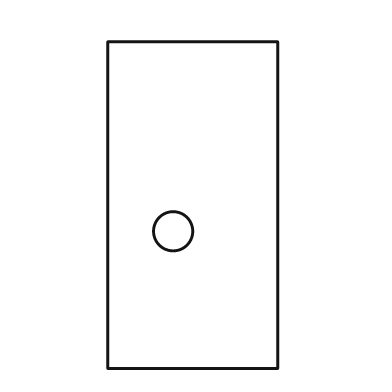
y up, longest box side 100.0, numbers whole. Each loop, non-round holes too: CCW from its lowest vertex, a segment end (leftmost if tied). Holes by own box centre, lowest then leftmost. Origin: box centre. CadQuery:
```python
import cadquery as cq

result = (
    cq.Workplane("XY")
    .moveTo(-26.0, -50.0)
    .lineTo(26.0, -50.0)
    .lineTo(26.0, 50.0)
    .lineTo(-26.0, 50.0)
    .close()
    .moveTo(-6.0, -8.0)
    .circle(6.0)
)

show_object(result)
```